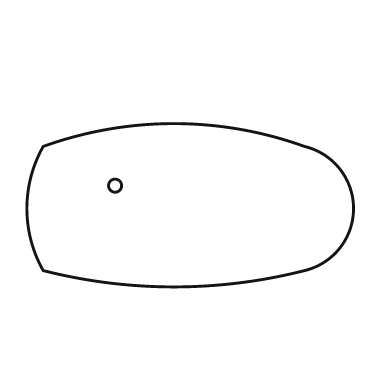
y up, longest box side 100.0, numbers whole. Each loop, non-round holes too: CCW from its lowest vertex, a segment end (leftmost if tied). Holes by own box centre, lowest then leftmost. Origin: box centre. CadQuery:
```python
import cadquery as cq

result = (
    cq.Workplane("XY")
    .moveTo(-45.0, -20.0)
    .threePointArc((-5.0, -25.0), (35.0, -20.0))
    .threePointArc((50.0, -1.0), (35.0, 18.0))
    .threePointArc((-5.0, 25.0), (-45.0, 18.0))
    .threePointArc((-50.0, -1.0), (-45.0, -20.0))
    .close()
    .moveTo(-23.0, 6.0)
    .circle(2.0)
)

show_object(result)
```